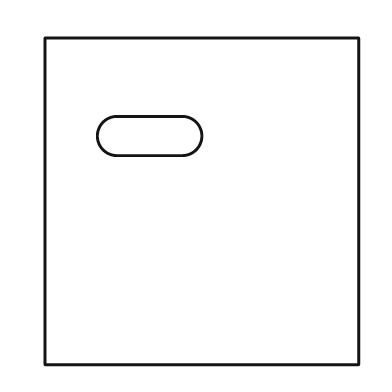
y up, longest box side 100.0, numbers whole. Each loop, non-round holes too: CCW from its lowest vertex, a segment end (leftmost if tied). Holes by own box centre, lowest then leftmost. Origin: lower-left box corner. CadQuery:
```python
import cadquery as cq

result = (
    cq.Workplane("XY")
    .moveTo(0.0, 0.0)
    .lineTo(96.0, 0.0)
    .lineTo(96.0, 100.0)
    .lineTo(0.0, 100.0)
    .close()
    .moveTo(22.0, 64.0)
    .lineTo(42.0, 64.0)
    .threePointArc((48.0, 70.0), (42.0, 76.0))
    .lineTo(22.0, 76.0)
    .threePointArc((16.0, 70.0), (22.0, 64.0))
    .close()
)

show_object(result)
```